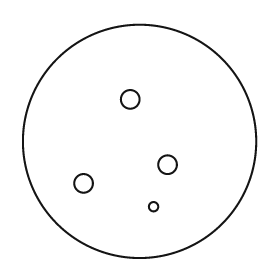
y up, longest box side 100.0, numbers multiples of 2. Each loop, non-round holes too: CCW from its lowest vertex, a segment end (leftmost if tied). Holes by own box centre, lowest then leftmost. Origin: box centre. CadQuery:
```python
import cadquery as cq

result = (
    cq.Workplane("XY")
    .moveTo(0.0, 0.0)
    .circle(50.0)
    .moveTo(6.0, -28.0)
    .circle(2.0)
    .moveTo(-24.0, -18.0)
    .circle(4.0)
    .moveTo(12.0, -10.0)
    .circle(4.0)
    .moveTo(-4.0, 18.0)
    .circle(4.0)
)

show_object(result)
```